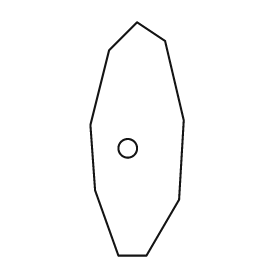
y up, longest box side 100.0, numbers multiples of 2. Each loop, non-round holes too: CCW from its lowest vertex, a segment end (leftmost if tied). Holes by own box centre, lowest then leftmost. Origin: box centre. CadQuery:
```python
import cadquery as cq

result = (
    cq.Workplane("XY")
    .moveTo(-8.0, -50.0)
    .lineTo(4.0, -50.0)
    .lineTo(18.0, -26.0)
    .lineTo(20.0, 8.0)
    .lineTo(12.0, 42.0)
    .lineTo(0.0, 50.0)
    .lineTo(-12.0, 38.0)
    .lineTo(-20.0, 6.0)
    .lineTo(-18.0, -22.0)
    .close()
    .moveTo(-4.0, -4.0)
    .circle(4.0)
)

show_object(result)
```